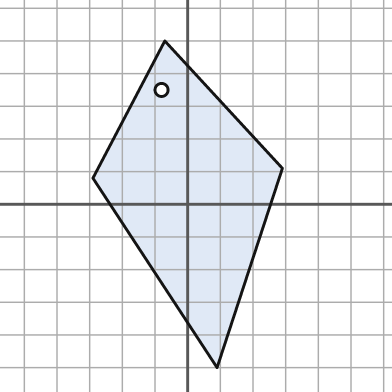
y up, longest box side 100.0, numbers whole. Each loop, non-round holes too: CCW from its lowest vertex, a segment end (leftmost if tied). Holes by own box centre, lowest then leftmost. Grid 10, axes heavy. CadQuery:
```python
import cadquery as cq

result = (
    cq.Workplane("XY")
    .moveTo(9.0, -50.0)
    .lineTo(29.0, 11.0)
    .lineTo(-7.0, 50.0)
    .lineTo(-29.0, 8.0)
    .close()
    .moveTo(-8.0, 35.0)
    .circle(2.0)
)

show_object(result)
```